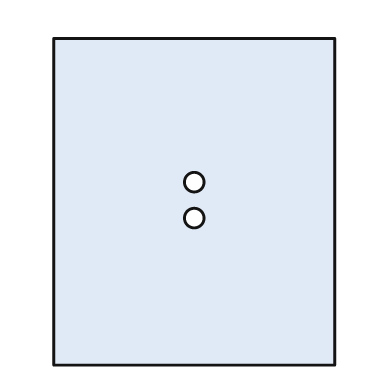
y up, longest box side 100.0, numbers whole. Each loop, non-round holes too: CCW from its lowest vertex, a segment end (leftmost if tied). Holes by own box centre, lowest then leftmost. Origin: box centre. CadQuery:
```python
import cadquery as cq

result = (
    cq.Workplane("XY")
    .moveTo(-43.0, -50.0)
    .lineTo(43.0, -50.0)
    .lineTo(43.0, 50.0)
    .lineTo(-43.0, 50.0)
    .close()
    .moveTo(0.0, -5.0)
    .circle(3.0)
    .moveTo(0.0, 6.0)
    .circle(3.0)
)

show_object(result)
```